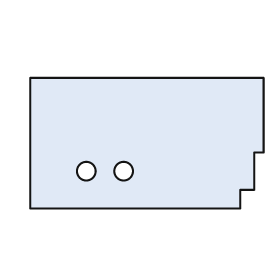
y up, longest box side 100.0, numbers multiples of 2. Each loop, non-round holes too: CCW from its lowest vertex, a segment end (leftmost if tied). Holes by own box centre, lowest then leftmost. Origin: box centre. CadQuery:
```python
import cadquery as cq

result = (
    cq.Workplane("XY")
    .moveTo(-50.0, -28.0)
    .lineTo(40.0, -28.0)
    .lineTo(40.0, -20.0)
    .lineTo(46.0, -20.0)
    .lineTo(46.0, -4.0)
    .lineTo(50.0, -4.0)
    .lineTo(50.0, 28.0)
    .lineTo(-50.0, 28.0)
    .close()
    .moveTo(-26.0, -12.0)
    .circle(4.0)
    .moveTo(-10.0, -12.0)
    .circle(4.0)
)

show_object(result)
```